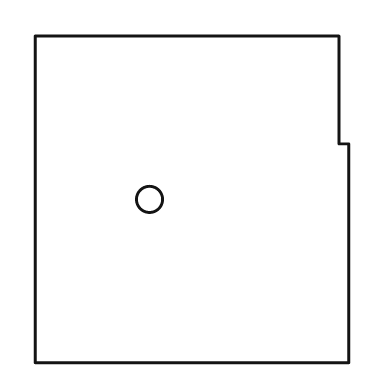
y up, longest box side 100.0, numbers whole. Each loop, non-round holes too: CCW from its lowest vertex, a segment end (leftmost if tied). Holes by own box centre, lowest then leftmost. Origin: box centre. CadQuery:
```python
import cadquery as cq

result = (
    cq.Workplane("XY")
    .moveTo(-48.0, -50.0)
    .lineTo(48.0, -50.0)
    .lineTo(48.0, 17.0)
    .lineTo(45.0, 17.0)
    .lineTo(45.0, 50.0)
    .lineTo(-48.0, 50.0)
    .close()
    .moveTo(-13.0, 0.0)
    .circle(4.0)
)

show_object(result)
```